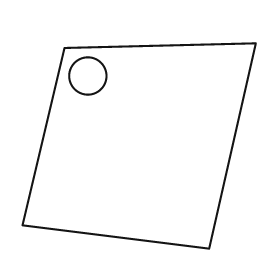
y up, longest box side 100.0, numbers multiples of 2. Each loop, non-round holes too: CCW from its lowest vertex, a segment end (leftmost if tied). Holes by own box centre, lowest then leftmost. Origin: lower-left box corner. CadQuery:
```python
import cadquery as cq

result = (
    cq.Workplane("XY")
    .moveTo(80.0, 0.0)
    .lineTo(100.0, 88.0)
    .lineTo(18.0, 86.0)
    .lineTo(0.0, 10.0)
    .close()
    .moveTo(28.0, 74.0)
    .circle(8.0)
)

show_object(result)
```